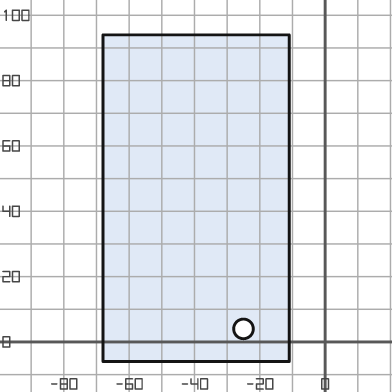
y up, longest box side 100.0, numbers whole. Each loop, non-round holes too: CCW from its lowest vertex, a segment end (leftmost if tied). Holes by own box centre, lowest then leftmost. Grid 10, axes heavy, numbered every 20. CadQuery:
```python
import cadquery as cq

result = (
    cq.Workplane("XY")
    .moveTo(-68.0, -6.0)
    .lineTo(-11.0, -6.0)
    .lineTo(-11.0, 94.0)
    .lineTo(-68.0, 94.0)
    .close()
    .moveTo(-25.0, 4.0)
    .circle(3.0)
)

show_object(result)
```